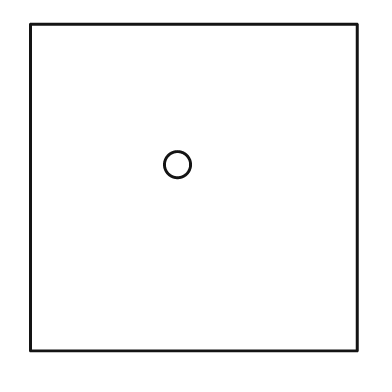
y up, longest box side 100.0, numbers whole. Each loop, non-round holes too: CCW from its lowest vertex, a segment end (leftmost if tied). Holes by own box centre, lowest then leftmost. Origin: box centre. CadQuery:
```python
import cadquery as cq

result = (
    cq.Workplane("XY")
    .moveTo(-50.0, -50.0)
    .lineTo(50.0, -50.0)
    .lineTo(50.0, 50.0)
    .lineTo(-50.0, 50.0)
    .close()
    .moveTo(-5.0, 7.0)
    .circle(4.0)
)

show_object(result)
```